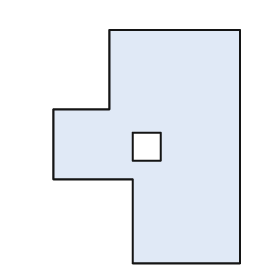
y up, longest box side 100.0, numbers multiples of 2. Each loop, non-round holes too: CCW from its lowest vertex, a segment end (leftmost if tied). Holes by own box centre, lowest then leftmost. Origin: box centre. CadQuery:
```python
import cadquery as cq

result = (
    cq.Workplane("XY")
    .moveTo(-6.0, -50.0)
    .lineTo(40.0, -50.0)
    .lineTo(40.0, 50.0)
    .lineTo(-16.0, 50.0)
    .lineTo(-16.0, 16.0)
    .lineTo(-40.0, 16.0)
    .lineTo(-40.0, -14.0)
    .lineTo(-6.0, -14.0)
    .close()
    .moveTo(-6.0, -6.0)
    .lineTo(6.0, -6.0)
    .lineTo(6.0, 6.0)
    .lineTo(-6.0, 6.0)
    .close()
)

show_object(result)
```